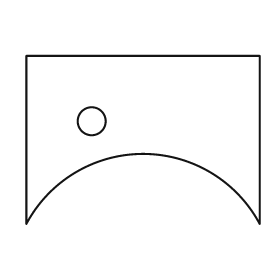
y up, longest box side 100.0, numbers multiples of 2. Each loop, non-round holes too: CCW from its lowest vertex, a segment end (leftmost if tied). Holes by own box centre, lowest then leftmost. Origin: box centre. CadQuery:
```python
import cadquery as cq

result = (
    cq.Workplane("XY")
    .moveTo(-50.0, -36.0)
    .threePointArc((0.0, -6.0), (50.0, -36.0))
    .lineTo(50.0, 36.0)
    .lineTo(-50.0, 36.0)
    .close()
    .moveTo(-22.0, 8.0)
    .circle(6.0)
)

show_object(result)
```